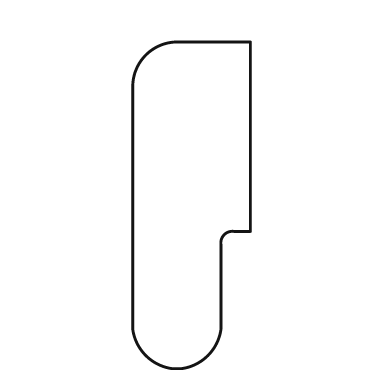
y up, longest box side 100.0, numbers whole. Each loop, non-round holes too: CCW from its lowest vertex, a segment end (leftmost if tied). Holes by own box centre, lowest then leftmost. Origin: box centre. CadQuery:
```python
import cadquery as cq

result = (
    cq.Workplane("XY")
    .moveTo(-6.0, -50.0)
    .lineTo(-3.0, -50.0)
    .threePointArc((5.0, -46.0), (9.0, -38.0))
    .lineTo(9.0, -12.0)
    .threePointArc((10.0, -9.0), (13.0, -8.0))
    .lineTo(18.0, -8.0)
    .lineTo(18.0, 50.0)
    .lineTo(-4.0, 50.0)
    .threePointArc((-14.0, 46.0), (-18.0, 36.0))
    .lineTo(-18.0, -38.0)
    .threePointArc((-14.0, -46.0), (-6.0, -50.0))
    .close()
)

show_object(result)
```